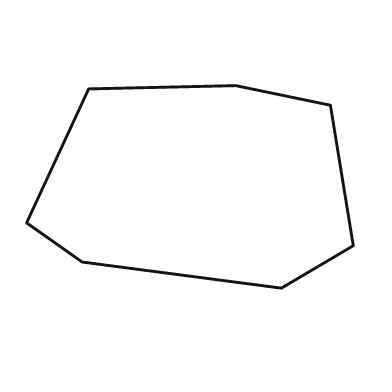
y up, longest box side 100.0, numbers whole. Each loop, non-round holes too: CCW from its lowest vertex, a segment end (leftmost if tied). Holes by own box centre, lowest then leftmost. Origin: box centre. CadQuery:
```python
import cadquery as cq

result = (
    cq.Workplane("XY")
    .moveTo(28.0, -31.0)
    .lineTo(50.0, -18.0)
    .lineTo(43.0, 25.0)
    .lineTo(14.0, 31.0)
    .lineTo(-31.0, 30.0)
    .lineTo(-50.0, -11.0)
    .lineTo(-33.0, -23.0)
    .close()
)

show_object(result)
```